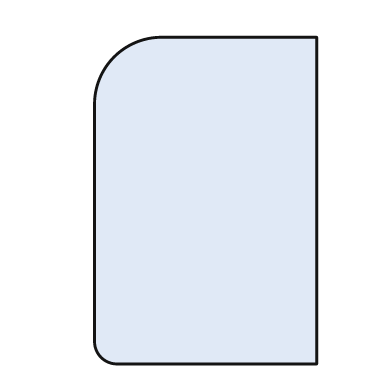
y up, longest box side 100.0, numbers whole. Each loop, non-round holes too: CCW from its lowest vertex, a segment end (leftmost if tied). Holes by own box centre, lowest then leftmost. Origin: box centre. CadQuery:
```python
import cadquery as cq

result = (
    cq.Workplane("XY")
    .moveTo(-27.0, -50.0)
    .lineTo(34.0, -50.0)
    .lineTo(34.0, 50.0)
    .lineTo(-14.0, 50.0)
    .threePointArc((-28.0, 44.0), (-34.0, 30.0))
    .lineTo(-34.0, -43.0)
    .threePointArc((-32.0, -48.0), (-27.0, -50.0))
    .close()
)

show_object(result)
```